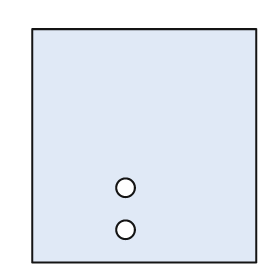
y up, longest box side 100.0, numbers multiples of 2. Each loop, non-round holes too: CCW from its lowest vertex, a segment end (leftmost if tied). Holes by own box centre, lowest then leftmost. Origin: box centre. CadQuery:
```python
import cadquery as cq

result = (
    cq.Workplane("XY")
    .moveTo(-48.0, -50.0)
    .lineTo(48.0, -50.0)
    .lineTo(48.0, 50.0)
    .lineTo(-48.0, 50.0)
    .close()
    .moveTo(-8.0, -36.0)
    .circle(4.0)
    .moveTo(-8.0, -18.0)
    .circle(4.0)
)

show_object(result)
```